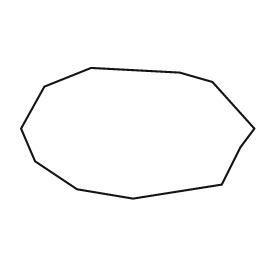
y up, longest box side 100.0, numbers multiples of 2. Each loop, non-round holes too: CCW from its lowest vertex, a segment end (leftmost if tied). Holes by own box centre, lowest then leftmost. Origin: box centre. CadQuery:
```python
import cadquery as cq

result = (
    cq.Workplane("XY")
    .moveTo(-2.0, -28.0)
    .lineTo(36.0, -22.0)
    .lineTo(44.0, -6.0)
    .lineTo(50.0, 2.0)
    .lineTo(32.0, 22.0)
    .lineTo(18.0, 26.0)
    .lineTo(-20.0, 28.0)
    .lineTo(-40.0, 20.0)
    .lineTo(-50.0, 2.0)
    .lineTo(-44.0, -12.0)
    .lineTo(-26.0, -24.0)
    .close()
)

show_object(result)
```